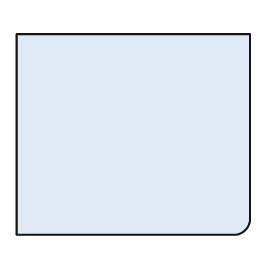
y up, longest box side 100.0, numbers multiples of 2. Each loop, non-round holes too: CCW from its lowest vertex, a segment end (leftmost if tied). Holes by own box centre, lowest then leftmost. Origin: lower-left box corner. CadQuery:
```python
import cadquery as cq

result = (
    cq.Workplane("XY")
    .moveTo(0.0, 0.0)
    .lineTo(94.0, 0.0)
    .threePointArc((98.0, 2.0), (100.0, 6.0))
    .lineTo(100.0, 86.0)
    .lineTo(0.0, 86.0)
    .close()
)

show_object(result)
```